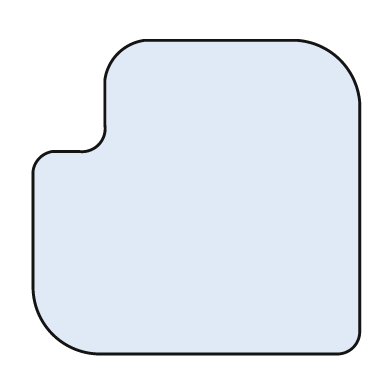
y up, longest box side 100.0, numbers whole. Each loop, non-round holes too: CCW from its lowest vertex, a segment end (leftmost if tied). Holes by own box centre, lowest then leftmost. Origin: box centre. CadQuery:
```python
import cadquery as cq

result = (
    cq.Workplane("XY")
    .moveTo(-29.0, -48.0)
    .lineTo(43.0, -48.0)
    .threePointArc((48.0, -46.0), (50.0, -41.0))
    .lineTo(50.0, 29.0)
    .threePointArc((44.0, 42.0), (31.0, 48.0))
    .lineTo(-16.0, 48.0)
    .threePointArc((-24.0, 44.0), (-28.0, 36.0))
    .lineTo(-28.0, 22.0)
    .threePointArc((-30.0, 16.0), (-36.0, 14.0))
    .lineTo(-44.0, 14.0)
    .threePointArc((-48.0, 12.0), (-50.0, 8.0))
    .lineTo(-50.0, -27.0)
    .threePointArc((-44.0, -42.0), (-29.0, -48.0))
    .close()
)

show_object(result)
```